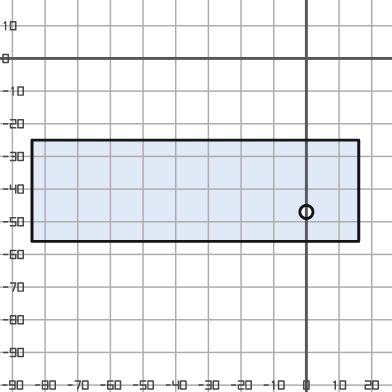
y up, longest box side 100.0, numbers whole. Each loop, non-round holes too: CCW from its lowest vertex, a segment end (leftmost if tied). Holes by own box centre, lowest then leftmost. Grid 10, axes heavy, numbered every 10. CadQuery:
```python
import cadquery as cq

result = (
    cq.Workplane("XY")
    .moveTo(-84.0, -56.0)
    .lineTo(16.0, -56.0)
    .lineTo(16.0, -25.0)
    .lineTo(-84.0, -25.0)
    .close()
    .moveTo(0.0, -47.0)
    .circle(2.0)
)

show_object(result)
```